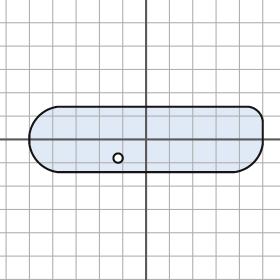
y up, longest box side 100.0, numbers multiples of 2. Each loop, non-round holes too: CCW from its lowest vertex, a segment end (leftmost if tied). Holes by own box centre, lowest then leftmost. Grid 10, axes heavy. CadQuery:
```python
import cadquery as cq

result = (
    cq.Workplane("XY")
    .moveTo(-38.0, -14.0)
    .lineTo(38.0, -14.0)
    .threePointArc((46.0, -10.0), (50.0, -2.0))
    .lineTo(50.0, 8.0)
    .threePointArc((48.0, 12.0), (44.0, 14.0))
    .lineTo(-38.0, 14.0)
    .threePointArc((-46.0, 10.0), (-50.0, 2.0))
    .lineTo(-50.0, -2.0)
    .threePointArc((-46.0, -10.0), (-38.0, -14.0))
    .close()
    .moveTo(-12.0, -8.0)
    .circle(2.0)
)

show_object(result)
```